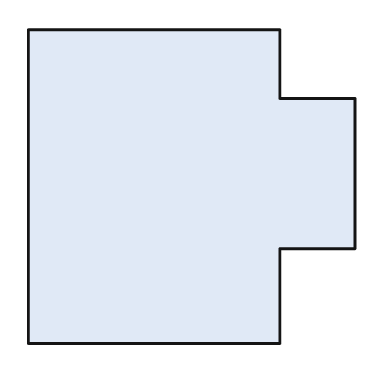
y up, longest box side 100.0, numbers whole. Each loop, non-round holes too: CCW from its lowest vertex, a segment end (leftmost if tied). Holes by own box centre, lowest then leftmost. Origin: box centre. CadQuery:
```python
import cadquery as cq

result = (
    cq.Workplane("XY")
    .moveTo(-50.0, -48.0)
    .lineTo(27.0, -48.0)
    .lineTo(27.0, -19.0)
    .lineTo(50.0, -19.0)
    .lineTo(50.0, 27.0)
    .lineTo(27.0, 27.0)
    .lineTo(27.0, 48.0)
    .lineTo(-50.0, 48.0)
    .close()
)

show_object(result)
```